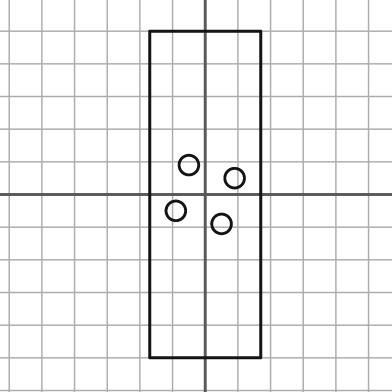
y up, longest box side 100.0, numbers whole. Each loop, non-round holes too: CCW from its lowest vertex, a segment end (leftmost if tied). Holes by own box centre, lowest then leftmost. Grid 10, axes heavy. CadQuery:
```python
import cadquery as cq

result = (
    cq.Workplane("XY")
    .moveTo(-17.0, -50.0)
    .lineTo(17.0, -50.0)
    .lineTo(17.0, 50.0)
    .lineTo(-17.0, 50.0)
    .close()
    .moveTo(5.0, -9.0)
    .circle(3.0)
    .moveTo(-9.0, -5.0)
    .circle(3.0)
    .moveTo(9.0, 5.0)
    .circle(3.0)
    .moveTo(-5.0, 9.0)
    .circle(3.0)
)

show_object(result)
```